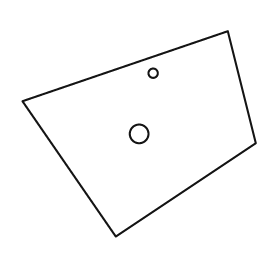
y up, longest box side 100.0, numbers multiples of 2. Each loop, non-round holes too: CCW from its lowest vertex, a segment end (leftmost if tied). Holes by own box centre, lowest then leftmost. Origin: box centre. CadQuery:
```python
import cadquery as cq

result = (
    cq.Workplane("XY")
    .moveTo(-10.0, -44.0)
    .lineTo(50.0, -4.0)
    .lineTo(38.0, 44.0)
    .lineTo(-50.0, 14.0)
    .close()
    .moveTo(0.0, 0.0)
    .circle(4.0)
    .moveTo(6.0, 26.0)
    .circle(2.0)
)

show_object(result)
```